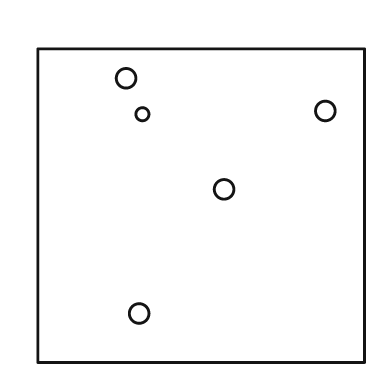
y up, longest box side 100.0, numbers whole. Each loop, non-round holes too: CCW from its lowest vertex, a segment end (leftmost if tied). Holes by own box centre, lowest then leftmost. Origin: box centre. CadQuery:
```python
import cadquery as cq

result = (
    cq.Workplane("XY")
    .moveTo(-50.0, -48.0)
    .lineTo(50.0, -48.0)
    .lineTo(50.0, 48.0)
    .lineTo(-50.0, 48.0)
    .close()
    .moveTo(-19.0, -33.0)
    .circle(3.0)
    .moveTo(7.0, 5.0)
    .circle(3.0)
    .moveTo(-18.0, 28.0)
    .circle(2.0)
    .moveTo(38.0, 29.0)
    .circle(3.0)
    .moveTo(-23.0, 39.0)
    .circle(3.0)
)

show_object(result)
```